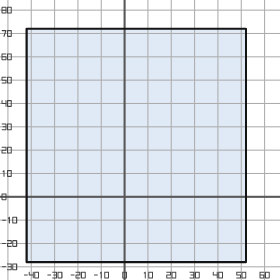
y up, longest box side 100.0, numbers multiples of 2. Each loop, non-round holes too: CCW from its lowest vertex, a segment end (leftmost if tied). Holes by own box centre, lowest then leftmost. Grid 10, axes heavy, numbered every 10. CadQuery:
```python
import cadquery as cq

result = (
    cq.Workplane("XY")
    .moveTo(-42.0, -28.0)
    .lineTo(52.0, -28.0)
    .lineTo(52.0, 72.0)
    .lineTo(-42.0, 72.0)
    .close()
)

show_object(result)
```